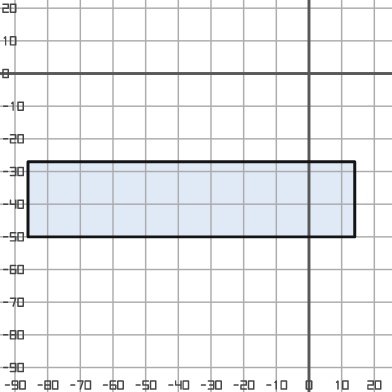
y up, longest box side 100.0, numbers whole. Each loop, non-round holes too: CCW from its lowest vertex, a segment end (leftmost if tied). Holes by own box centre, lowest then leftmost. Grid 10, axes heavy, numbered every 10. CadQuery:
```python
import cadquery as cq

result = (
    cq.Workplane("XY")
    .moveTo(-86.0, -50.0)
    .lineTo(14.0, -50.0)
    .lineTo(14.0, -27.0)
    .lineTo(-86.0, -27.0)
    .close()
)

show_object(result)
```